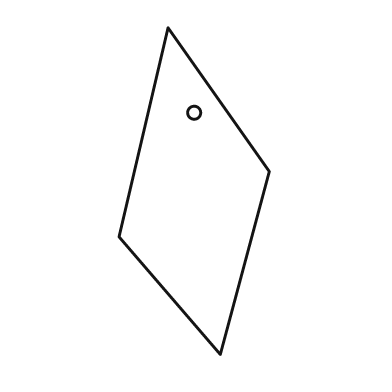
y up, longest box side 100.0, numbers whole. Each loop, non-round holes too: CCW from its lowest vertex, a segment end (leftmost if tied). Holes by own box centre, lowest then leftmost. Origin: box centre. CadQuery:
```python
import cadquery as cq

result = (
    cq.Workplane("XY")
    .moveTo(8.0, -50.0)
    .lineTo(23.0, 6.0)
    .lineTo(-8.0, 50.0)
    .lineTo(-23.0, -14.0)
    .close()
    .moveTo(0.0, 24.0)
    .circle(2.0)
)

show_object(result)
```